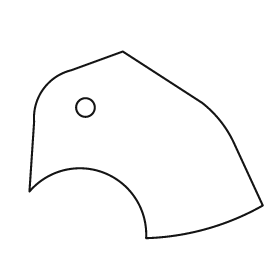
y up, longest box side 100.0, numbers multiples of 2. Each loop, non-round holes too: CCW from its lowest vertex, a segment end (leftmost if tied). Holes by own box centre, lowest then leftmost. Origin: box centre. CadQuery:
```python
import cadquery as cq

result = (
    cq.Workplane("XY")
    .moveTo(0.0, -40.0)
    .threePointArc((26.0, -36.0), (50.0, -26.0))
    .lineTo(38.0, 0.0)
    .threePointArc((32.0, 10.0), (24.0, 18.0))
    .lineTo(-10.0, 40.0)
    .lineTo(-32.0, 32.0)
    .threePointArc((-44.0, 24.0), (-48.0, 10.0))
    .lineTo(-50.0, -20.0)
    .threePointArc((-18.0, -12.0), (0.0, -40.0))
    .close()
    .moveTo(-26.0, 16.0)
    .circle(4.0)
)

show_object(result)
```